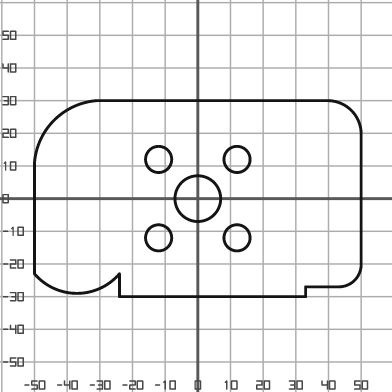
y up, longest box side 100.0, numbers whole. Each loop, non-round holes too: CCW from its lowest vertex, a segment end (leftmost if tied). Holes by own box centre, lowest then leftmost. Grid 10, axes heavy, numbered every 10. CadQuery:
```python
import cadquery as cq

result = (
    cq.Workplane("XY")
    .moveTo(-24.0, -30.0)
    .lineTo(33.0, -30.0)
    .lineTo(33.0, -27.0)
    .lineTo(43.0, -27.0)
    .threePointArc((48.0, -25.0), (50.0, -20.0))
    .lineTo(50.0, 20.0)
    .threePointArc((47.0, 27.0), (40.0, 30.0))
    .lineTo(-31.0, 30.0)
    .threePointArc((-44.0, 24.0), (-50.0, 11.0))
    .lineTo(-50.0, -23.0)
    .threePointArc((-37.0, -29.0), (-24.0, -23.0))
    .close()
    .moveTo(-12.0, -12.0)
    .circle(4.0)
    .moveTo(12.0, -12.0)
    .circle(4.0)
    .moveTo(0.0, 0.0)
    .circle(7.0)
    .moveTo(-12.0, 12.0)
    .circle(4.0)
    .moveTo(12.0, 12.0)
    .circle(4.0)
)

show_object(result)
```